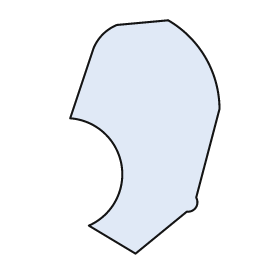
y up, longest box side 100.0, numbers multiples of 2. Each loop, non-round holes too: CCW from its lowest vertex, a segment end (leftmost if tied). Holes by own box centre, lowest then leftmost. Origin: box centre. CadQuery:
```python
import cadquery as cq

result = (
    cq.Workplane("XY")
    .moveTo(-4.0, -50.0)
    .lineTo(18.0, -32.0)
    .threePointArc((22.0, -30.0), (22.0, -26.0))
    .lineTo(32.0, 12.0)
    .threePointArc((26.0, 34.0), (10.0, 50.0))
    .lineTo(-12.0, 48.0)
    .threePointArc((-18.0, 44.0), (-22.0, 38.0))
    .lineTo(-32.0, 8.0)
    .threePointArc((-10.0, -12.0), (-24.0, -38.0))
    .close()
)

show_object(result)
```